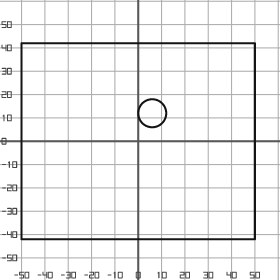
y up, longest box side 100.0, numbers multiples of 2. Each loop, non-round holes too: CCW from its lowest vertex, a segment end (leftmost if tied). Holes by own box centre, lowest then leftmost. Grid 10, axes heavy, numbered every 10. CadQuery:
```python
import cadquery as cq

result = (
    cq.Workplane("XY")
    .moveTo(-50.0, -42.0)
    .lineTo(50.0, -42.0)
    .lineTo(50.0, 42.0)
    .lineTo(-50.0, 42.0)
    .close()
    .moveTo(6.0, 12.0)
    .circle(6.0)
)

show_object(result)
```